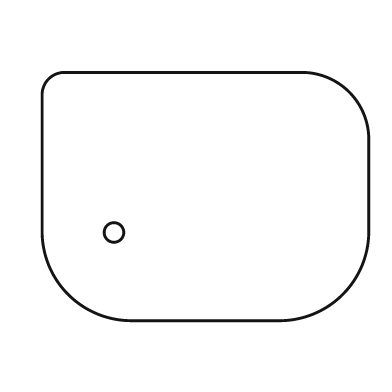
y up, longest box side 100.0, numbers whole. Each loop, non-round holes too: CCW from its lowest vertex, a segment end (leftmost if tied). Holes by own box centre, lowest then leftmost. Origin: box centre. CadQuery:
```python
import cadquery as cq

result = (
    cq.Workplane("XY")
    .moveTo(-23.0, -38.0)
    .lineTo(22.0, -38.0)
    .threePointArc((42.0, -30.0), (50.0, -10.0))
    .lineTo(50.0, 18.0)
    .threePointArc((44.0, 32.0), (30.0, 38.0))
    .lineTo(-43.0, 38.0)
    .threePointArc((-48.0, 36.0), (-50.0, 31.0))
    .lineTo(-50.0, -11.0)
    .threePointArc((-42.0, -30.0), (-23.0, -38.0))
    .close()
    .moveTo(-28.0, -11.0)
    .circle(3.0)
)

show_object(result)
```